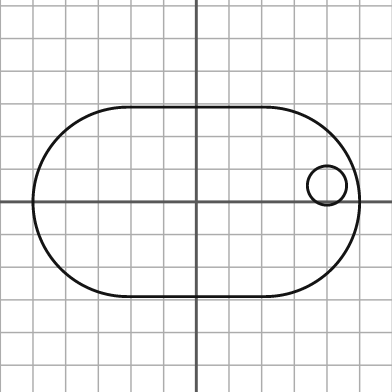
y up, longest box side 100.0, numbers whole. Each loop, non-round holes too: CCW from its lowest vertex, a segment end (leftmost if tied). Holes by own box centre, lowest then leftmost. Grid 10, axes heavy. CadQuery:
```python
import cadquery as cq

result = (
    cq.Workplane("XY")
    .moveTo(-21.0, -29.0)
    .lineTo(21.0, -29.0)
    .threePointArc((50.0, 0.0), (21.0, 29.0))
    .lineTo(-21.0, 29.0)
    .threePointArc((-50.0, 0.0), (-21.0, -29.0))
    .close()
    .moveTo(40.0, 5.0)
    .circle(6.0)
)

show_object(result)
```